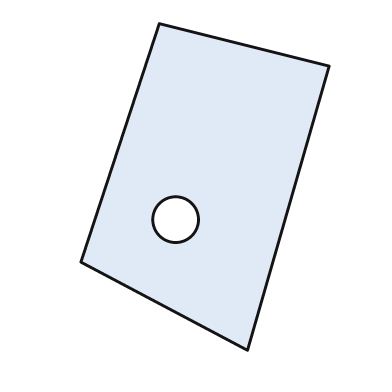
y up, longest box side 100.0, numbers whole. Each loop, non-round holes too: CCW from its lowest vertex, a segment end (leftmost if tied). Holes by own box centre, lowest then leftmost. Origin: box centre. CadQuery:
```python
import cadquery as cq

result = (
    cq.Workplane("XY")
    .moveTo(13.0, -50.0)
    .lineTo(38.0, 37.0)
    .lineTo(-14.0, 50.0)
    .lineTo(-38.0, -23.0)
    .close()
    .moveTo(-9.0, -10.0)
    .circle(7.0)
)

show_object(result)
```